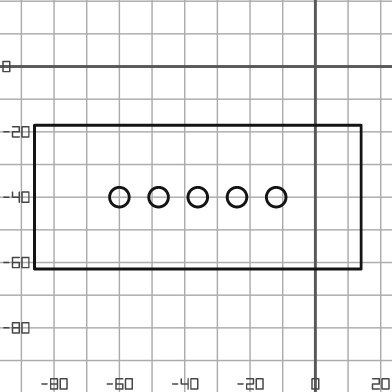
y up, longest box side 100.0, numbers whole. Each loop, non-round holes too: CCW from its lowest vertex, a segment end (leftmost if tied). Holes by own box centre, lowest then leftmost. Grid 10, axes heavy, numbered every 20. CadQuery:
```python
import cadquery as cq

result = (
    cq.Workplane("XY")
    .moveTo(-86.0, -62.0)
    .lineTo(14.0, -62.0)
    .lineTo(14.0, -18.0)
    .lineTo(-86.0, -18.0)
    .close()
    .moveTo(-60.0, -40.0)
    .circle(3.0)
    .moveTo(-48.0, -40.0)
    .circle(3.0)
    .moveTo(-36.0, -40.0)
    .circle(3.0)
    .moveTo(-24.0, -40.0)
    .circle(3.0)
    .moveTo(-12.0, -40.0)
    .circle(3.0)
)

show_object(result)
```